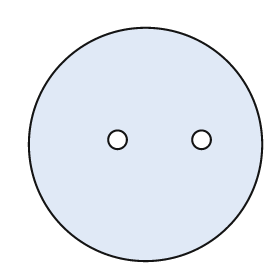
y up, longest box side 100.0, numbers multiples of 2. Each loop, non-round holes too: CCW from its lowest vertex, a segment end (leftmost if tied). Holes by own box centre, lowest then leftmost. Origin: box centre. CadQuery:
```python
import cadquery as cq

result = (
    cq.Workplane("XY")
    .moveTo(0.0, 0.0)
    .circle(50.0)
    .moveTo(-12.0, 2.0)
    .circle(4.0)
    .moveTo(24.0, 2.0)
    .circle(4.0)
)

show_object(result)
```